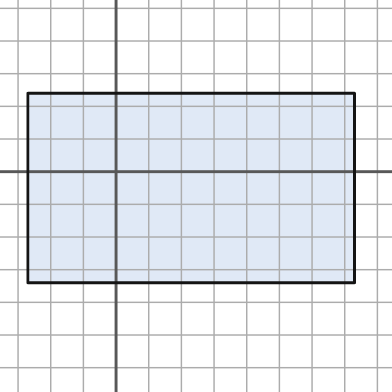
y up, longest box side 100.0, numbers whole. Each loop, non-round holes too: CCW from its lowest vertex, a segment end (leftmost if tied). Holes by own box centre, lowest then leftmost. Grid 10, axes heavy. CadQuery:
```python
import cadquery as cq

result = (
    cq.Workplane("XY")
    .moveTo(-27.0, -34.0)
    .lineTo(73.0, -34.0)
    .lineTo(73.0, 24.0)
    .lineTo(-27.0, 24.0)
    .close()
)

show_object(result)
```